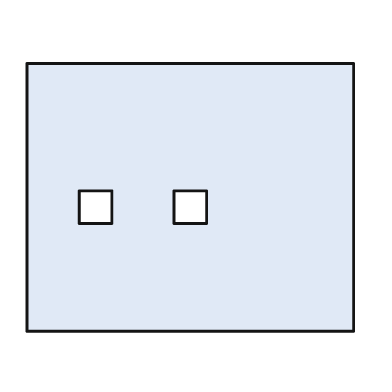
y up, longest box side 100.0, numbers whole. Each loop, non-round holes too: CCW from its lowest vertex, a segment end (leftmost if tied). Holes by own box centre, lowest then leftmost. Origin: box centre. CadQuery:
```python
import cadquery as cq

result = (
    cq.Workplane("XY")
    .moveTo(-50.0, -41.0)
    .lineTo(50.0, -41.0)
    .lineTo(50.0, 41.0)
    .lineTo(-50.0, 41.0)
    .close()
    .moveTo(-34.0, -8.0)
    .lineTo(-24.0, -8.0)
    .lineTo(-24.0, 2.0)
    .lineTo(-34.0, 2.0)
    .close()
    .moveTo(-5.0, -8.0)
    .lineTo(5.0, -8.0)
    .lineTo(5.0, 2.0)
    .lineTo(-5.0, 2.0)
    .close()
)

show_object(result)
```